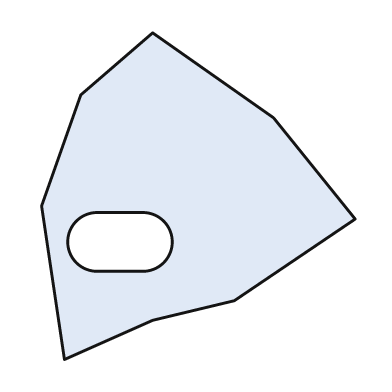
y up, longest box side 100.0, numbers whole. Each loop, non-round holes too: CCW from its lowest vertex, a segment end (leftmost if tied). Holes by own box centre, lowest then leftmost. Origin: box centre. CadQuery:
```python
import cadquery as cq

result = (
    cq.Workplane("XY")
    .moveTo(-41.0, -50.0)
    .lineTo(-14.0, -38.0)
    .lineTo(11.0, -32.0)
    .lineTo(48.0, -7.0)
    .lineTo(23.0, 24.0)
    .lineTo(-14.0, 50.0)
    .lineTo(-36.0, 31.0)
    .lineTo(-48.0, -3.0)
    .close()
    .moveTo(-31.0, -23.0)
    .lineTo(-17.0, -23.0)
    .threePointArc((-8.0, -14.0), (-17.0, -5.0))
    .lineTo(-31.0, -5.0)
    .threePointArc((-40.0, -14.0), (-31.0, -23.0))
    .close()
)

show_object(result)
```